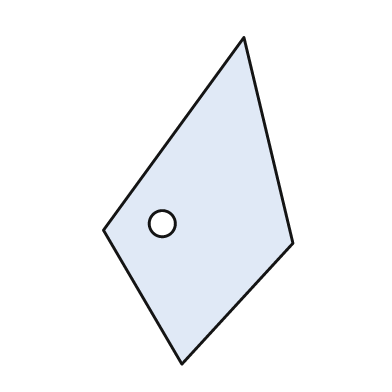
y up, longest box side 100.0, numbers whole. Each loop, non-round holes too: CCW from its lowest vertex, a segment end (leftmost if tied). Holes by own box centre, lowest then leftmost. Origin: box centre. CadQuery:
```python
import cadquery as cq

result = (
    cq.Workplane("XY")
    .moveTo(-5.0, -50.0)
    .lineTo(29.0, -13.0)
    .lineTo(14.0, 50.0)
    .lineTo(-29.0, -9.0)
    .close()
    .moveTo(-11.0, -7.0)
    .circle(4.0)
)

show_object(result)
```